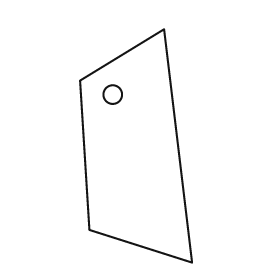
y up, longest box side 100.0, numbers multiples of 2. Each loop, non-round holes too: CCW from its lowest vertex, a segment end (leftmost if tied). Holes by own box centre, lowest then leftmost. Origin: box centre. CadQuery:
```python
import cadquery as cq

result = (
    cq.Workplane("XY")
    .moveTo(24.0, -50.0)
    .lineTo(12.0, 50.0)
    .lineTo(-24.0, 28.0)
    .lineTo(-20.0, -36.0)
    .close()
    .moveTo(-10.0, 22.0)
    .circle(4.0)
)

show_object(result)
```